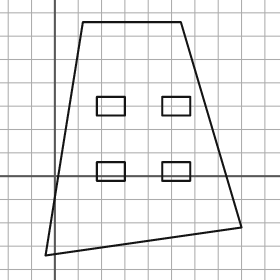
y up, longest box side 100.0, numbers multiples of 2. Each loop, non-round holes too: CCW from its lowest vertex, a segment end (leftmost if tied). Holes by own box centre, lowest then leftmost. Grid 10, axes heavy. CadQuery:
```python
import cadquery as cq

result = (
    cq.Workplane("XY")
    .moveTo(-4.0, -34.0)
    .lineTo(80.0, -22.0)
    .lineTo(54.0, 66.0)
    .lineTo(12.0, 66.0)
    .close()
    .moveTo(18.0, -2.0)
    .lineTo(30.0, -2.0)
    .lineTo(30.0, 6.0)
    .lineTo(18.0, 6.0)
    .close()
    .moveTo(46.0, -2.0)
    .lineTo(58.0, -2.0)
    .lineTo(58.0, 6.0)
    .lineTo(46.0, 6.0)
    .close()
    .moveTo(18.0, 26.0)
    .lineTo(30.0, 26.0)
    .lineTo(30.0, 34.0)
    .lineTo(18.0, 34.0)
    .close()
    .moveTo(46.0, 26.0)
    .lineTo(58.0, 26.0)
    .lineTo(58.0, 34.0)
    .lineTo(46.0, 34.0)
    .close()
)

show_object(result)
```